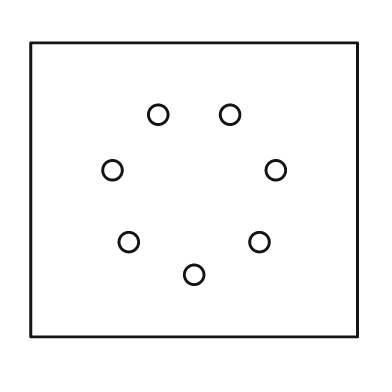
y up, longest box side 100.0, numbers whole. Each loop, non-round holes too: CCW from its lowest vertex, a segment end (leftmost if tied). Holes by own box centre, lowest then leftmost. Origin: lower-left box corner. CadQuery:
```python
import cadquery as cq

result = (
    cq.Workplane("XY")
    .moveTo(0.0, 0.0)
    .lineTo(100.0, 0.0)
    .lineTo(100.0, 90.0)
    .lineTo(0.0, 90.0)
    .close()
    .moveTo(50.0, 19.0)
    .circle(3.0)
    .moveTo(30.0, 29.0)
    .circle(3.0)
    .moveTo(70.0, 29.0)
    .circle(3.0)
    .moveTo(25.0, 51.0)
    .circle(3.0)
    .moveTo(75.0, 51.0)
    .circle(3.0)
    .moveTo(39.0, 68.0)
    .circle(3.0)
    .moveTo(61.0, 68.0)
    .circle(3.0)
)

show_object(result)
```